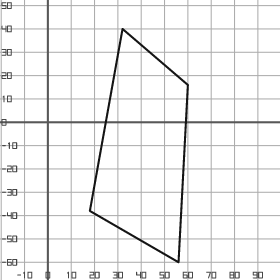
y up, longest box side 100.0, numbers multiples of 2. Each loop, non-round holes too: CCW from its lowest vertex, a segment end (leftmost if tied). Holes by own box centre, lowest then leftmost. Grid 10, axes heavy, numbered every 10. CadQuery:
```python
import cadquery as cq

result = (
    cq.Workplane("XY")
    .moveTo(56.0, -60.0)
    .lineTo(60.0, 16.0)
    .lineTo(32.0, 40.0)
    .lineTo(18.0, -38.0)
    .close()
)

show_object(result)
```